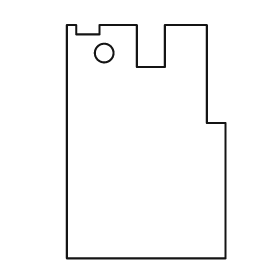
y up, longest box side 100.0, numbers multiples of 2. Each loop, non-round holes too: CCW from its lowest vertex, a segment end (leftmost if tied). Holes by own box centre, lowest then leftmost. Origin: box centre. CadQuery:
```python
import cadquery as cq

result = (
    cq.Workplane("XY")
    .moveTo(-34.0, -50.0)
    .lineTo(34.0, -50.0)
    .lineTo(34.0, 8.0)
    .lineTo(26.0, 8.0)
    .lineTo(26.0, 50.0)
    .lineTo(8.0, 50.0)
    .lineTo(8.0, 32.0)
    .lineTo(-4.0, 32.0)
    .lineTo(-4.0, 50.0)
    .lineTo(-20.0, 50.0)
    .lineTo(-20.0, 46.0)
    .lineTo(-30.0, 46.0)
    .lineTo(-30.0, 50.0)
    .lineTo(-34.0, 50.0)
    .close()
    .moveTo(-18.0, 38.0)
    .circle(4.0)
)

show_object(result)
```